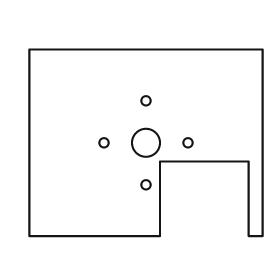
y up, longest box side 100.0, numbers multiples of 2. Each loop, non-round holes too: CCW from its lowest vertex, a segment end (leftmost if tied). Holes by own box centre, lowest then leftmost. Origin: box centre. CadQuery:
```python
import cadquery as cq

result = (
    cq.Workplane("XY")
    .moveTo(-50.0, -40.0)
    .lineTo(6.0, -40.0)
    .lineTo(6.0, -8.0)
    .lineTo(44.0, -8.0)
    .lineTo(44.0, -40.0)
    .lineTo(50.0, -40.0)
    .lineTo(50.0, 40.0)
    .lineTo(-50.0, 40.0)
    .close()
    .moveTo(0.0, -18.0)
    .circle(2.0)
    .moveTo(-18.0, 0.0)
    .circle(2.0)
    .moveTo(0.0, 0.0)
    .circle(6.0)
    .moveTo(18.0, 0.0)
    .circle(2.0)
    .moveTo(0.0, 18.0)
    .circle(2.0)
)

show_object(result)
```